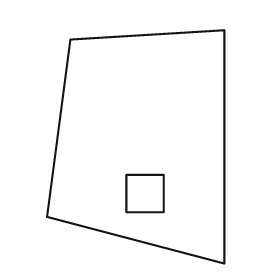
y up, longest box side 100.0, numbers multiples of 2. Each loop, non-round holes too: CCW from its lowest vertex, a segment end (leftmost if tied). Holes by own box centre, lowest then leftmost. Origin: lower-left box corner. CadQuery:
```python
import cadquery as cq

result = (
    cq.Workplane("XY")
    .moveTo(76.0, 0.0)
    .lineTo(76.0, 100.0)
    .lineTo(10.0, 96.0)
    .lineTo(0.0, 20.0)
    .close()
    .moveTo(34.0, 22.0)
    .lineTo(50.0, 22.0)
    .lineTo(50.0, 38.0)
    .lineTo(34.0, 38.0)
    .close()
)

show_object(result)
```